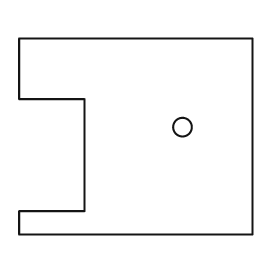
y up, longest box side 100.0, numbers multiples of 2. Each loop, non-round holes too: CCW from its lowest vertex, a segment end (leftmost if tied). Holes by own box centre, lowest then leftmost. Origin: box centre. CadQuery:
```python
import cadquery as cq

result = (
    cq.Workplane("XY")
    .moveTo(-50.0, -42.0)
    .lineTo(50.0, -42.0)
    .lineTo(50.0, 42.0)
    .lineTo(-50.0, 42.0)
    .lineTo(-50.0, 16.0)
    .lineTo(-22.0, 16.0)
    .lineTo(-22.0, -32.0)
    .lineTo(-50.0, -32.0)
    .close()
    .moveTo(20.0, 4.0)
    .circle(4.0)
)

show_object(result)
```